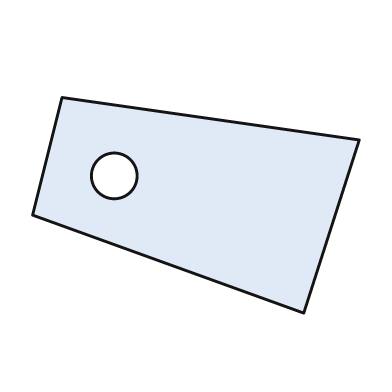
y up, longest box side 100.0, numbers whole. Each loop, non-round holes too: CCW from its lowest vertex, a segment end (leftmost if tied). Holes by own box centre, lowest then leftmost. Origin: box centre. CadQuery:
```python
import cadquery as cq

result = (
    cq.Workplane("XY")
    .moveTo(33.0, -33.0)
    .lineTo(50.0, 20.0)
    .lineTo(-41.0, 33.0)
    .lineTo(-50.0, -3.0)
    .close()
    .moveTo(-25.0, 9.0)
    .circle(7.0)
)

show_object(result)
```